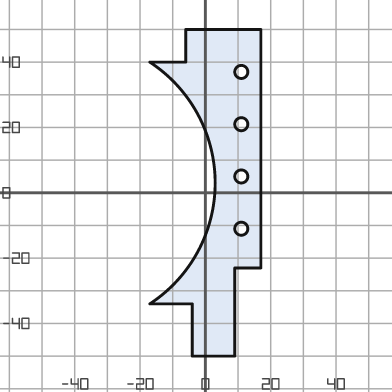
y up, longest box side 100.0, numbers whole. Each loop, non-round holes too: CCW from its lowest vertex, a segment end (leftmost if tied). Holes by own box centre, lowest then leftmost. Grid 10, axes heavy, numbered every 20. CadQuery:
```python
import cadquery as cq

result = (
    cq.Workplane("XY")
    .moveTo(-4.0, -50.0)
    .lineTo(9.0, -50.0)
    .lineTo(9.0, -23.0)
    .lineTo(17.0, -23.0)
    .lineTo(17.0, 50.0)
    .lineTo(-6.0, 50.0)
    .lineTo(-6.0, 40.0)
    .lineTo(-17.0, 40.0)
    .threePointArc((3.0, 3.0), (-17.0, -34.0))
    .lineTo(-4.0, -34.0)
    .close()
    .moveTo(11.0, -11.0)
    .circle(2.0)
    .moveTo(11.0, 5.0)
    .circle(2.0)
    .moveTo(11.0, 21.0)
    .circle(2.0)
    .moveTo(11.0, 37.0)
    .circle(2.0)
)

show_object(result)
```